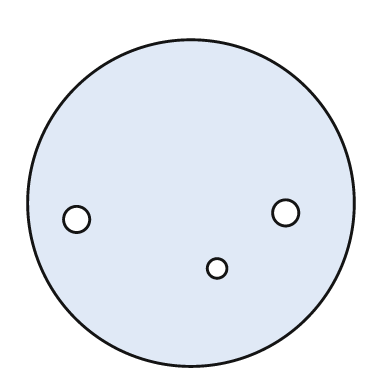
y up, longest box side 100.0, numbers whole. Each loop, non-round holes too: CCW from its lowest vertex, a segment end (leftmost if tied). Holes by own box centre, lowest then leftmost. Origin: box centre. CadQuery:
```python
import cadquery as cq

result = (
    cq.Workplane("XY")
    .moveTo(0.0, 0.0)
    .circle(50.0)
    .moveTo(8.0, -20.0)
    .circle(3.0)
    .moveTo(-35.0, -5.0)
    .circle(4.0)
    .moveTo(29.0, -3.0)
    .circle(4.0)
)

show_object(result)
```